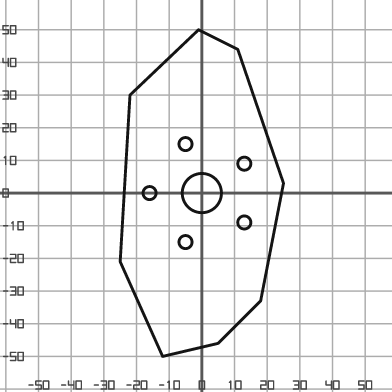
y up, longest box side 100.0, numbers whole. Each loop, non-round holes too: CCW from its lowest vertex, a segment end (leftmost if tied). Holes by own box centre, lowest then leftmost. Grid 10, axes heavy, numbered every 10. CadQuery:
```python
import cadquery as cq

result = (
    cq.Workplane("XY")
    .moveTo(-12.0, -50.0)
    .lineTo(5.0, -46.0)
    .lineTo(18.0, -33.0)
    .lineTo(25.0, 3.0)
    .lineTo(11.0, 44.0)
    .lineTo(-1.0, 50.0)
    .lineTo(-22.0, 30.0)
    .lineTo(-25.0, -21.0)
    .close()
    .moveTo(-5.0, -15.0)
    .circle(2.0)
    .moveTo(13.0, -9.0)
    .circle(2.0)
    .moveTo(-16.0, 0.0)
    .circle(2.0)
    .moveTo(0.0, 0.0)
    .circle(6.0)
    .moveTo(13.0, 9.0)
    .circle(2.0)
    .moveTo(-5.0, 15.0)
    .circle(2.0)
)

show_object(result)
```